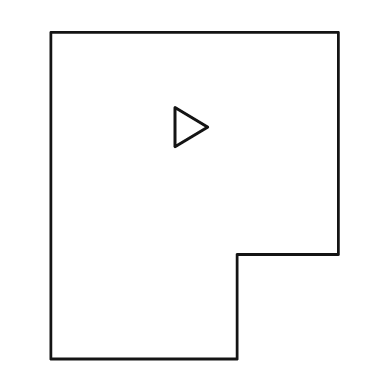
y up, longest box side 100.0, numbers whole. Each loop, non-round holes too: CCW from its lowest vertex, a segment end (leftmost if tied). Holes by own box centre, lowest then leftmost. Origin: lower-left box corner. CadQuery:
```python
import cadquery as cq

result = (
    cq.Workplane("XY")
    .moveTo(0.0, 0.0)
    .lineTo(57.0, 0.0)
    .lineTo(57.0, 32.0)
    .lineTo(88.0, 32.0)
    .lineTo(88.0, 100.0)
    .lineTo(0.0, 100.0)
    .close()
    .moveTo(38.0, 65.0)
    .lineTo(48.0, 71.0)
    .lineTo(38.0, 77.0)
    .close()
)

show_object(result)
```